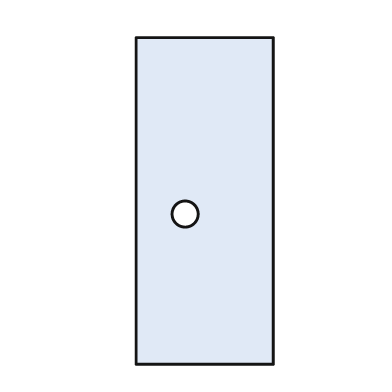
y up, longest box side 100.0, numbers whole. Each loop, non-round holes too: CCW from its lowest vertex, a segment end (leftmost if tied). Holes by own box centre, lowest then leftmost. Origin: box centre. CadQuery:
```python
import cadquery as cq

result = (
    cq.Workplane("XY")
    .moveTo(-21.0, -50.0)
    .lineTo(21.0, -50.0)
    .lineTo(21.0, 50.0)
    .lineTo(-21.0, 50.0)
    .close()
    .moveTo(-6.0, -4.0)
    .circle(4.0)
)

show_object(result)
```